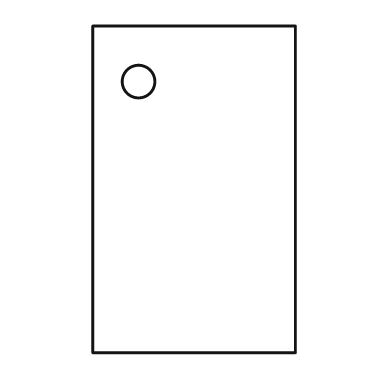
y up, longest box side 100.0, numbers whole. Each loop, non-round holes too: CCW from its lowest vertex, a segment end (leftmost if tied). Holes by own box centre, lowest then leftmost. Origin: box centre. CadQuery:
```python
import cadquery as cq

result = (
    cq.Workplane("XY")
    .moveTo(-31.0, -50.0)
    .lineTo(31.0, -50.0)
    .lineTo(31.0, 50.0)
    .lineTo(-31.0, 50.0)
    .close()
    .moveTo(-17.0, 33.0)
    .circle(5.0)
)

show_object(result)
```